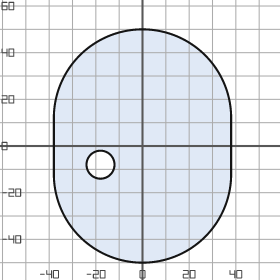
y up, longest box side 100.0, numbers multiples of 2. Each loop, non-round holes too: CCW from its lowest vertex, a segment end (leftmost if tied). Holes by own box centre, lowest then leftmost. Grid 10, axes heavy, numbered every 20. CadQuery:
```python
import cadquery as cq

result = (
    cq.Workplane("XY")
    .moveTo(-38.0, -12.0)
    .threePointArc((0.0, -50.0), (38.0, -12.0))
    .lineTo(38.0, 12.0)
    .threePointArc((0.0, 50.0), (-38.0, 12.0))
    .close()
    .moveTo(-18.0, -8.0)
    .circle(6.0)
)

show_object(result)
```